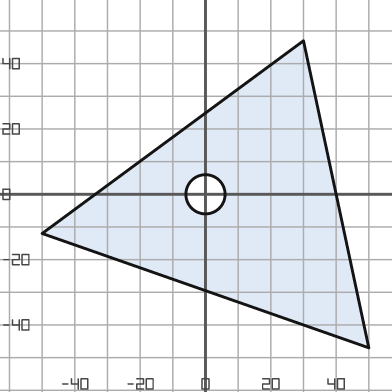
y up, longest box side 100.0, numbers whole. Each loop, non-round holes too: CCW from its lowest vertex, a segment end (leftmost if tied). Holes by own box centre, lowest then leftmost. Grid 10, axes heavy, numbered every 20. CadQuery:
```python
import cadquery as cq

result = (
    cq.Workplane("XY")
    .moveTo(50.0, -47.0)
    .lineTo(30.0, 47.0)
    .lineTo(-50.0, -12.0)
    .close()
    .moveTo(0.0, 0.0)
    .circle(6.0)
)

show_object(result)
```